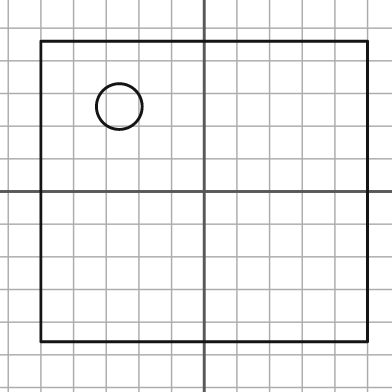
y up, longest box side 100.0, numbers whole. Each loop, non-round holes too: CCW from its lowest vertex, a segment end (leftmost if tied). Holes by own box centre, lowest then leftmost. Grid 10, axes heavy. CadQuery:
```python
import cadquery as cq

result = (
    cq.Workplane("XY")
    .moveTo(-50.0, -46.0)
    .lineTo(50.0, -46.0)
    .lineTo(50.0, 46.0)
    .lineTo(-50.0, 46.0)
    .close()
    .moveTo(-26.0, 26.0)
    .circle(7.0)
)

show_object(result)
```